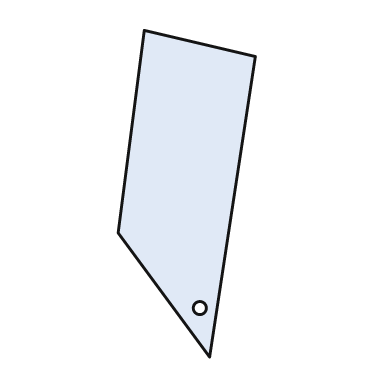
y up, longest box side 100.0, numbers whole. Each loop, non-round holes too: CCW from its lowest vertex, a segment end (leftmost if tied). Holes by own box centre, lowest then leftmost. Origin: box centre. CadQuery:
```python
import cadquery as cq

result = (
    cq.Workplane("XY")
    .moveTo(7.0, -50.0)
    .lineTo(21.0, 42.0)
    .lineTo(-13.0, 50.0)
    .lineTo(-21.0, -12.0)
    .close()
    .moveTo(4.0, -35.0)
    .circle(2.0)
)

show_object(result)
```